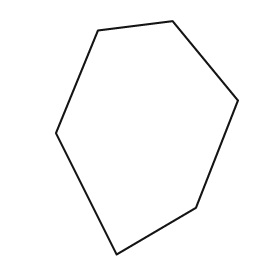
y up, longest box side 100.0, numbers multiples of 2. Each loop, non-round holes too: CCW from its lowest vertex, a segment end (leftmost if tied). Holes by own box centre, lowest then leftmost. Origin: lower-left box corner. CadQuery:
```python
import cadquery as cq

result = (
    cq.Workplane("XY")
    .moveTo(26.0, 0.0)
    .lineTo(60.0, 20.0)
    .lineTo(78.0, 66.0)
    .lineTo(50.0, 100.0)
    .lineTo(18.0, 96.0)
    .lineTo(0.0, 52.0)
    .close()
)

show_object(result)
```